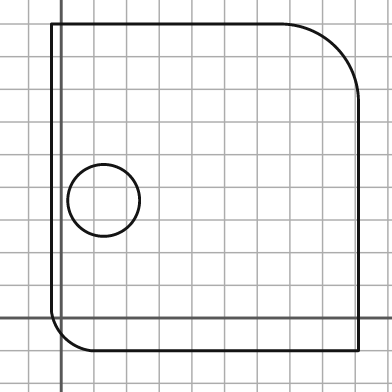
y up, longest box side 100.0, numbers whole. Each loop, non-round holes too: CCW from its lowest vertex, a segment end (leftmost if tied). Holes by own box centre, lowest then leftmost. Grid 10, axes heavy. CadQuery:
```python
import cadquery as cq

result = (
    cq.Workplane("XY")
    .moveTo(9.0, -10.0)
    .lineTo(91.0, -10.0)
    .lineTo(91.0, 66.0)
    .threePointArc((84.0, 83.0), (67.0, 90.0))
    .lineTo(-3.0, 90.0)
    .lineTo(-3.0, 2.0)
    .threePointArc((1.0, -6.0), (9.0, -10.0))
    .close()
    .moveTo(13.0, 36.0)
    .circle(11.0)
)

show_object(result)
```